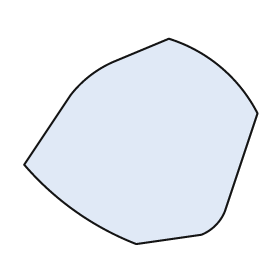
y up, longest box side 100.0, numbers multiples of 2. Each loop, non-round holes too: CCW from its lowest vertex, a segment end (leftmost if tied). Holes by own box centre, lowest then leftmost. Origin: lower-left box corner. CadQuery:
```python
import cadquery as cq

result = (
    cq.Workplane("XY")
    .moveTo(48.0, 0.0)
    .lineTo(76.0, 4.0)
    .threePointArc((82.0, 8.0), (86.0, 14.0))
    .lineTo(100.0, 56.0)
    .threePointArc((84.0, 76.0), (62.0, 88.0))
    .lineTo(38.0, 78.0)
    .threePointArc((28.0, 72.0), (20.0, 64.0))
    .lineTo(0.0, 34.0)
    .threePointArc((22.0, 14.0), (48.0, 0.0))
    .close()
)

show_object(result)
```